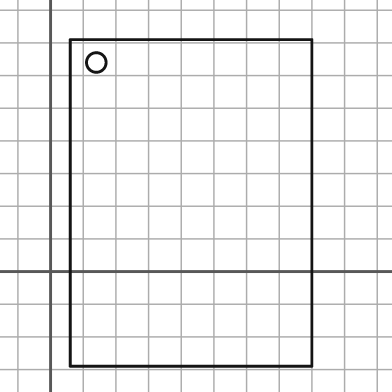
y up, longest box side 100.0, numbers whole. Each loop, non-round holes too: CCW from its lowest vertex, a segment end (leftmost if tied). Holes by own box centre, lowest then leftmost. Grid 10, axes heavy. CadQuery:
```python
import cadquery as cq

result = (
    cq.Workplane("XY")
    .moveTo(6.0, -29.0)
    .lineTo(80.0, -29.0)
    .lineTo(80.0, 71.0)
    .lineTo(6.0, 71.0)
    .close()
    .moveTo(14.0, 64.0)
    .circle(3.0)
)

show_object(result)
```